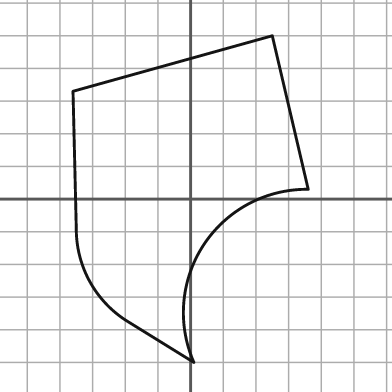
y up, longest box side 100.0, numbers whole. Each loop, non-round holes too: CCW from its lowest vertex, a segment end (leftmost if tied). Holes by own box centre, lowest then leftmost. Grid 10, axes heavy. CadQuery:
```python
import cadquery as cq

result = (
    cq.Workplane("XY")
    .moveTo(1.0, -50.0)
    .threePointArc((4.0, -14.0), (36.0, 3.0))
    .lineTo(25.0, 50.0)
    .lineTo(-36.0, 33.0)
    .lineTo(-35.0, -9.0)
    .threePointArc((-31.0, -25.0), (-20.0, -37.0))
    .close()
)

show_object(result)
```